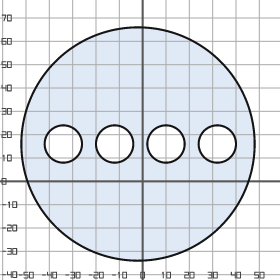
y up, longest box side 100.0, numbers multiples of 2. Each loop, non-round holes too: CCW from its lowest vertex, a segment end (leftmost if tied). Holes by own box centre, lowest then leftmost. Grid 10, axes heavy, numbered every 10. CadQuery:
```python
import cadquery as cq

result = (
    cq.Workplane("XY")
    .moveTo(-2.0, 16.0)
    .circle(50.0)
    .moveTo(-34.0, 16.0)
    .circle(8.0)
    .moveTo(-12.0, 16.0)
    .circle(8.0)
    .moveTo(10.0, 16.0)
    .circle(8.0)
    .moveTo(32.0, 16.0)
    .circle(8.0)
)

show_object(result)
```